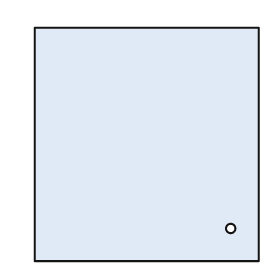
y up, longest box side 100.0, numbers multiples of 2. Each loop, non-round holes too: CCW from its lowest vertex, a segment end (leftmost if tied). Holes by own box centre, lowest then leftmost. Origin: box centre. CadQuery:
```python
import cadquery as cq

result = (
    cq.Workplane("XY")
    .moveTo(-48.0, -50.0)
    .lineTo(48.0, -50.0)
    .lineTo(48.0, 50.0)
    .lineTo(-48.0, 50.0)
    .close()
    .moveTo(36.0, -36.0)
    .circle(2.0)
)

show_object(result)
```